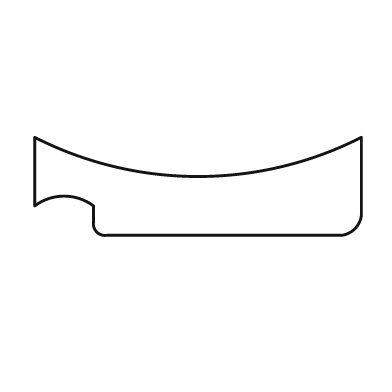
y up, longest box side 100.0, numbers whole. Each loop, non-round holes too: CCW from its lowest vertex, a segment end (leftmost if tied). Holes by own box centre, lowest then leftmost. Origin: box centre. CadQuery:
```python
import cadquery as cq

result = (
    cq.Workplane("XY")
    .moveTo(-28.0, -15.0)
    .lineTo(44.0, -15.0)
    .threePointArc((48.0, -13.0), (50.0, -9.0))
    .lineTo(50.0, 15.0)
    .threePointArc((0.0, 3.0), (-50.0, 15.0))
    .lineTo(-50.0, -6.0)
    .threePointArc((-41.0, -3.0), (-32.0, -6.0))
    .lineTo(-32.0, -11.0)
    .threePointArc((-31.0, -14.0), (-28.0, -15.0))
    .close()
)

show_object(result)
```